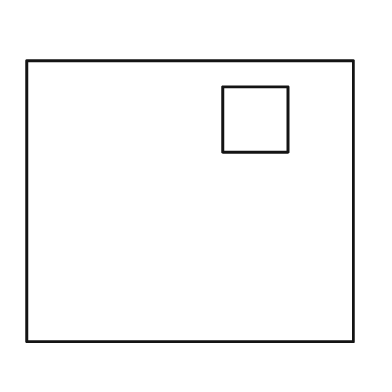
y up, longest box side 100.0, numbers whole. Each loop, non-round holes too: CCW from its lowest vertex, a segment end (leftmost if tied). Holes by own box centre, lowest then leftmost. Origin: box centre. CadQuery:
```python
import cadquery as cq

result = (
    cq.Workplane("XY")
    .moveTo(-50.0, -43.0)
    .lineTo(50.0, -43.0)
    .lineTo(50.0, 43.0)
    .lineTo(-50.0, 43.0)
    .close()
    .moveTo(10.0, 15.0)
    .lineTo(30.0, 15.0)
    .lineTo(30.0, 35.0)
    .lineTo(10.0, 35.0)
    .close()
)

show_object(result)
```